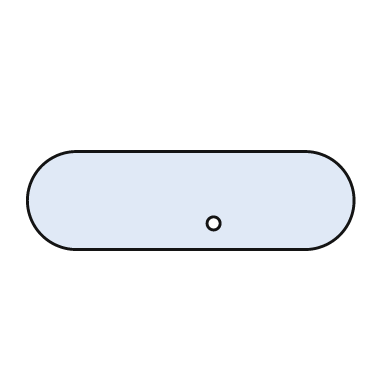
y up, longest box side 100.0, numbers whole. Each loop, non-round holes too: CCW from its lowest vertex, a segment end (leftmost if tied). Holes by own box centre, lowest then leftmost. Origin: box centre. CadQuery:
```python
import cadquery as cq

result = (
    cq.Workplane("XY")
    .moveTo(-35.0, -15.0)
    .lineTo(35.0, -15.0)
    .threePointArc((50.0, 0.0), (35.0, 15.0))
    .lineTo(-35.0, 15.0)
    .threePointArc((-50.0, 0.0), (-35.0, -15.0))
    .close()
    .moveTo(7.0, -7.0)
    .circle(2.0)
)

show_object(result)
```